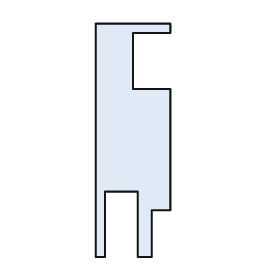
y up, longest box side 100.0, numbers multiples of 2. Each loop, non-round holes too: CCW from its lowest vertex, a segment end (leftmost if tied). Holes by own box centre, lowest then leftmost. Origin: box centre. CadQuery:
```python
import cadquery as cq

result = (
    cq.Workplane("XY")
    .moveTo(-16.0, -50.0)
    .lineTo(-12.0, -50.0)
    .lineTo(-12.0, -22.0)
    .lineTo(2.0, -22.0)
    .lineTo(2.0, -50.0)
    .lineTo(8.0, -50.0)
    .lineTo(8.0, -30.0)
    .lineTo(16.0, -30.0)
    .lineTo(16.0, 22.0)
    .lineTo(0.0, 22.0)
    .lineTo(0.0, 46.0)
    .lineTo(16.0, 46.0)
    .lineTo(16.0, 50.0)
    .lineTo(-16.0, 50.0)
    .close()
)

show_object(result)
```